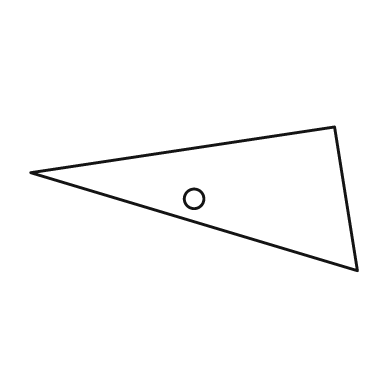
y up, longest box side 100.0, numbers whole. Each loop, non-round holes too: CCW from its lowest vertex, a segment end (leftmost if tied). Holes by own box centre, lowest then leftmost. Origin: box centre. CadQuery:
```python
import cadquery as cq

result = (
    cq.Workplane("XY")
    .moveTo(50.0, -22.0)
    .lineTo(43.0, 22.0)
    .lineTo(-50.0, 8.0)
    .close()
    .moveTo(0.0, 0.0)
    .circle(3.0)
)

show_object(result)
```